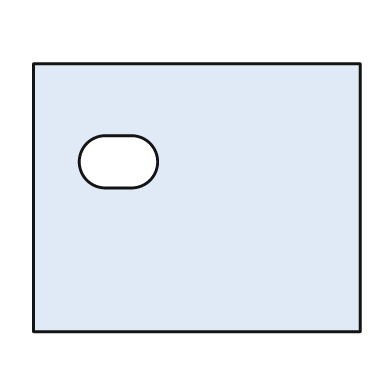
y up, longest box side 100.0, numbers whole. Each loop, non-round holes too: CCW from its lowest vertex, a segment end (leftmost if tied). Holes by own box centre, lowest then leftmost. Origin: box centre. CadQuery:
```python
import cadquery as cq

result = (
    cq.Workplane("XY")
    .moveTo(-50.0, -41.0)
    .lineTo(50.0, -41.0)
    .lineTo(50.0, 41.0)
    .lineTo(-50.0, 41.0)
    .close()
    .moveTo(-28.0, 3.0)
    .lineTo(-20.0, 3.0)
    .threePointArc((-12.0, 11.0), (-20.0, 19.0))
    .lineTo(-28.0, 19.0)
    .threePointArc((-36.0, 11.0), (-28.0, 3.0))
    .close()
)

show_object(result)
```